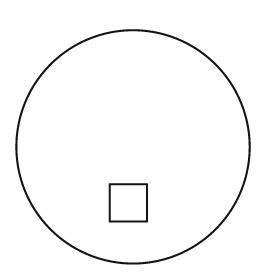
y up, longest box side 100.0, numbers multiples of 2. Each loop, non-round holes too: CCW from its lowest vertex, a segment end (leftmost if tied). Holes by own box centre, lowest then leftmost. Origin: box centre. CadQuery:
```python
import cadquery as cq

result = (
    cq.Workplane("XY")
    .moveTo(0.0, 0.0)
    .circle(50.0)
    .moveTo(-10.0, -32.0)
    .lineTo(6.0, -32.0)
    .lineTo(6.0, -16.0)
    .lineTo(-10.0, -16.0)
    .close()
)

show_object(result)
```